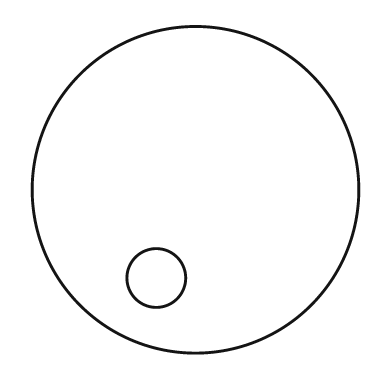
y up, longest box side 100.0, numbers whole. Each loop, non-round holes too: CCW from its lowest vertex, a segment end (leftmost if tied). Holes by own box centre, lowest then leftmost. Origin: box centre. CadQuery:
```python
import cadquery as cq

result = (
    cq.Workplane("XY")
    .moveTo(0.0, 0.0)
    .circle(50.0)
    .moveTo(-12.0, -27.0)
    .circle(9.0)
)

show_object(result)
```